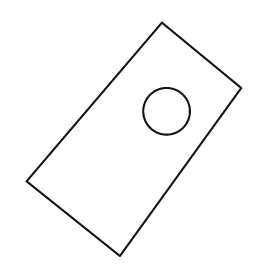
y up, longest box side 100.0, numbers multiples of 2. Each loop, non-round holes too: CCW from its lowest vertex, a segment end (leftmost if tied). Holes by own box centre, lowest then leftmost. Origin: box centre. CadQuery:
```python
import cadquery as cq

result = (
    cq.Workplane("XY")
    .moveTo(-6.0, -50.0)
    .lineTo(46.0, 22.0)
    .lineTo(12.0, 50.0)
    .lineTo(-46.0, -18.0)
    .close()
    .moveTo(14.0, 12.0)
    .circle(10.0)
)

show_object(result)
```